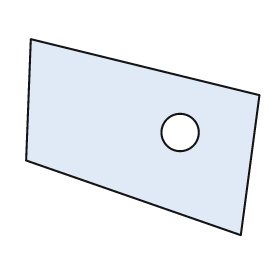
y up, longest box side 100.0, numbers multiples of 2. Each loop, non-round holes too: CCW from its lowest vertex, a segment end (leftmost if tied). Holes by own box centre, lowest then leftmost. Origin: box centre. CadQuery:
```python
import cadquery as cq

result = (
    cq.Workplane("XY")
    .moveTo(42.0, -42.0)
    .lineTo(50.0, 18.0)
    .lineTo(-48.0, 42.0)
    .lineTo(-50.0, -10.0)
    .close()
    .moveTo(16.0, 2.0)
    .circle(8.0)
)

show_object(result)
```